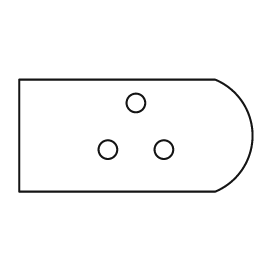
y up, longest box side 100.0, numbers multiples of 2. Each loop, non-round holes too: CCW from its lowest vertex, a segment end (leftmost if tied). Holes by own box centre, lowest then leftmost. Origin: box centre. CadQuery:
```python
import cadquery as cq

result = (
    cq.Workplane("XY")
    .moveTo(-50.0, -24.0)
    .lineTo(34.0, -24.0)
    .threePointArc((50.0, 0.0), (34.0, 24.0))
    .lineTo(-50.0, 24.0)
    .close()
    .moveTo(-12.0, -6.0)
    .circle(4.0)
    .moveTo(12.0, -6.0)
    .circle(4.0)
    .moveTo(0.0, 14.0)
    .circle(4.0)
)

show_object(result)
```